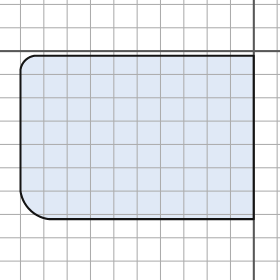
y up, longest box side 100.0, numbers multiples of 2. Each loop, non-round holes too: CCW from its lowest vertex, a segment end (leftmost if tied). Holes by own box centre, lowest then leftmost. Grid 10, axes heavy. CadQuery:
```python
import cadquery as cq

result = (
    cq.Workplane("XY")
    .moveTo(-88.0, -72.0)
    .lineTo(0.0, -72.0)
    .lineTo(0.0, -2.0)
    .lineTo(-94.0, -2.0)
    .threePointArc((-98.0, -4.0), (-100.0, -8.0))
    .lineTo(-100.0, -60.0)
    .threePointArc((-96.0, -68.0), (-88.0, -72.0))
    .close()
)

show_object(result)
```